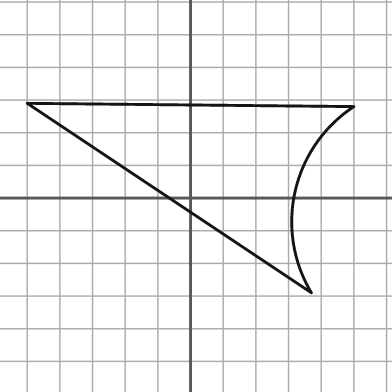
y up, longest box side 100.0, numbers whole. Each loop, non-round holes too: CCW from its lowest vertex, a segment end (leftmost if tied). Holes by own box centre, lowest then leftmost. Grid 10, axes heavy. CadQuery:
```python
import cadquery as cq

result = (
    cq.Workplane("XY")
    .moveTo(37.0, -29.0)
    .threePointArc((32.0, 2.0), (50.0, 28.0))
    .lineTo(-50.0, 29.0)
    .close()
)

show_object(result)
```